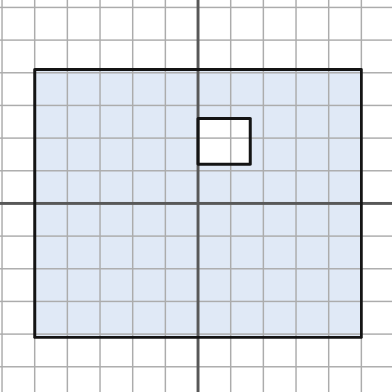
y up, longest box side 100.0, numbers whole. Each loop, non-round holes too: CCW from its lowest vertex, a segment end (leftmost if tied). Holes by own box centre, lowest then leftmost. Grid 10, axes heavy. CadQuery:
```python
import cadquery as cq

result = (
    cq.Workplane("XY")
    .moveTo(-50.0, -41.0)
    .lineTo(50.0, -41.0)
    .lineTo(50.0, 41.0)
    .lineTo(-50.0, 41.0)
    .close()
    .moveTo(0.0, 12.0)
    .lineTo(16.0, 12.0)
    .lineTo(16.0, 26.0)
    .lineTo(0.0, 26.0)
    .close()
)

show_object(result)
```